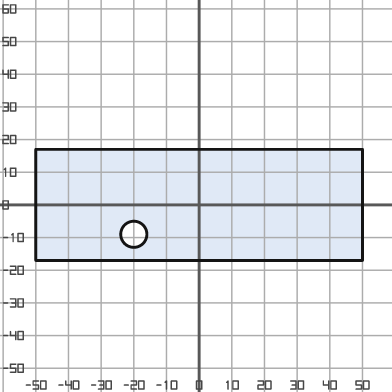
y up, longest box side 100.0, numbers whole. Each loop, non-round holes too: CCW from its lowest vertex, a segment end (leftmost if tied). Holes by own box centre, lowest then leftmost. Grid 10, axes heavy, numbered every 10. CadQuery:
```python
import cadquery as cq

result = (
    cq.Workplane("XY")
    .moveTo(-50.0, -17.0)
    .lineTo(50.0, -17.0)
    .lineTo(50.0, 17.0)
    .lineTo(-50.0, 17.0)
    .close()
    .moveTo(-20.0, -9.0)
    .circle(4.0)
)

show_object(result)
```